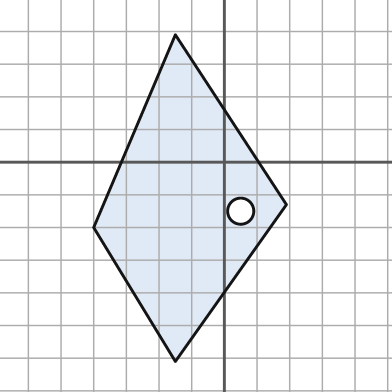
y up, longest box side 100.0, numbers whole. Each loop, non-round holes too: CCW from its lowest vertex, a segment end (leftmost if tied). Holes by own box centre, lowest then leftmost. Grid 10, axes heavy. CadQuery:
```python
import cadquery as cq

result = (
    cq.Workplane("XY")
    .moveTo(-15.0, -61.0)
    .lineTo(19.0, -13.0)
    .lineTo(-15.0, 39.0)
    .lineTo(-40.0, -20.0)
    .close()
    .moveTo(5.0, -15.0)
    .circle(4.0)
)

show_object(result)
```